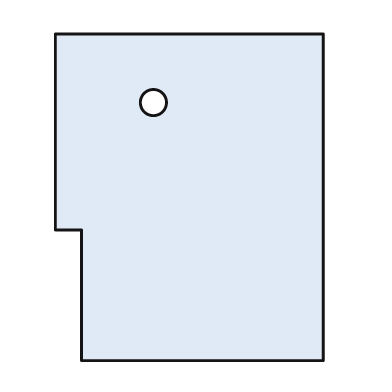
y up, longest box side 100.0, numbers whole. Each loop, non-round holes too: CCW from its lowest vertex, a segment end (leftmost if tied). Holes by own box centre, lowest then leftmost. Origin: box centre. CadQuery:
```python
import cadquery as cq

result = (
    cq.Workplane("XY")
    .moveTo(-33.0, -50.0)
    .lineTo(41.0, -50.0)
    .lineTo(41.0, 50.0)
    .lineTo(-41.0, 50.0)
    .lineTo(-41.0, -10.0)
    .lineTo(-33.0, -10.0)
    .close()
    .moveTo(-11.0, 29.0)
    .circle(4.0)
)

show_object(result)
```